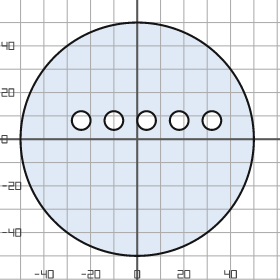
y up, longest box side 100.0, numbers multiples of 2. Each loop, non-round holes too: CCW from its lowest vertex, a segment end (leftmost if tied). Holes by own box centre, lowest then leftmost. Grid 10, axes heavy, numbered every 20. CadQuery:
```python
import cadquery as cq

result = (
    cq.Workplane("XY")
    .moveTo(0.0, 0.0)
    .circle(50.0)
    .moveTo(-24.0, 8.0)
    .circle(4.0)
    .moveTo(-10.0, 8.0)
    .circle(4.0)
    .moveTo(4.0, 8.0)
    .circle(4.0)
    .moveTo(18.0, 8.0)
    .circle(4.0)
    .moveTo(32.0, 8.0)
    .circle(4.0)
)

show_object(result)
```